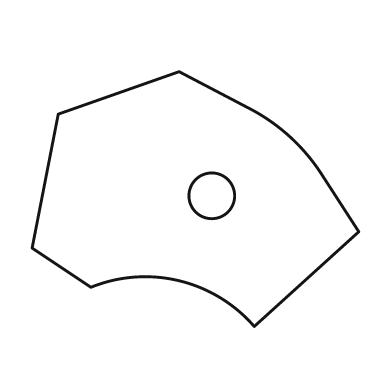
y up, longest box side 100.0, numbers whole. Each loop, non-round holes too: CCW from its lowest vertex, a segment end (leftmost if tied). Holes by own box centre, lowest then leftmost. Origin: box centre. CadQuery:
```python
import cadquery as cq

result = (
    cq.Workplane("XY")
    .moveTo(18.0, -39.0)
    .lineTo(50.0, -10.0)
    .lineTo(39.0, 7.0)
    .threePointArc((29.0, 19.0), (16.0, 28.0))
    .lineTo(-5.0, 39.0)
    .lineTo(-42.0, 26.0)
    .lineTo(-50.0, -15.0)
    .lineTo(-32.0, -27.0)
    .threePointArc((-5.0, -25.0), (18.0, -39.0))
    .close()
    .moveTo(5.0, 1.0)
    .circle(7.0)
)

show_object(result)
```